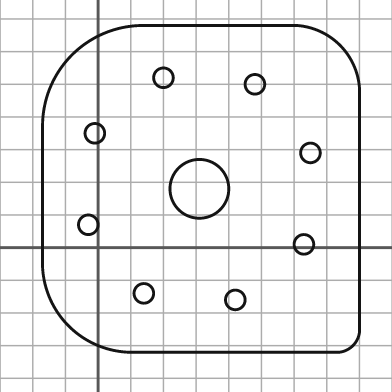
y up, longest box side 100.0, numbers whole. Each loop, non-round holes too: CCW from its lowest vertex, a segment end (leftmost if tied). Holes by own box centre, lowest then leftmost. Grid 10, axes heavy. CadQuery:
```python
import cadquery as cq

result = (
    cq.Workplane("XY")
    .moveTo(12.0, -32.0)
    .lineTo(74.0, -32.0)
    .threePointArc((78.0, -30.0), (80.0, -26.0))
    .lineTo(80.0, 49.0)
    .threePointArc((74.0, 62.0), (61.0, 68.0))
    .lineTo(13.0, 68.0)
    .threePointArc((-8.0, 59.0), (-17.0, 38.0))
    .lineTo(-17.0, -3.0)
    .threePointArc((-9.0, -24.0), (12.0, -32.0))
    .close()
    .moveTo(42.0, -16.0)
    .circle(3.0)
    .moveTo(14.0, -14.0)
    .circle(3.0)
    .moveTo(63.0, 1.0)
    .circle(3.0)
    .moveTo(-3.0, 7.0)
    .circle(3.0)
    .moveTo(31.0, 18.0)
    .circle(9.0)
    .moveTo(65.0, 29.0)
    .circle(3.0)
    .moveTo(-1.0, 35.0)
    .circle(3.0)
    .moveTo(48.0, 50.0)
    .circle(3.0)
    .moveTo(20.0, 52.0)
    .circle(3.0)
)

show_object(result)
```